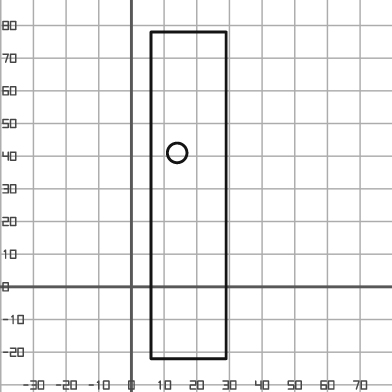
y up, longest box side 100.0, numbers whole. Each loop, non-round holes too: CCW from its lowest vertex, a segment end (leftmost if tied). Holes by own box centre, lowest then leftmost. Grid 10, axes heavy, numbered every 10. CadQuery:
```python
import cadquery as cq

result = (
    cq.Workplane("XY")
    .moveTo(6.0, -22.0)
    .lineTo(29.0, -22.0)
    .lineTo(29.0, 78.0)
    .lineTo(6.0, 78.0)
    .close()
    .moveTo(14.0, 41.0)
    .circle(3.0)
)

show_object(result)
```